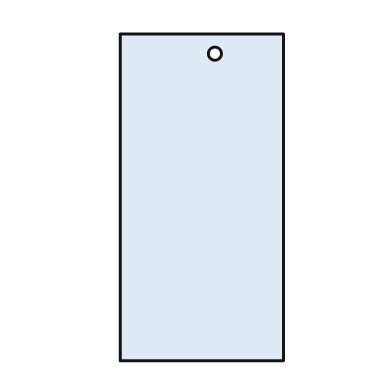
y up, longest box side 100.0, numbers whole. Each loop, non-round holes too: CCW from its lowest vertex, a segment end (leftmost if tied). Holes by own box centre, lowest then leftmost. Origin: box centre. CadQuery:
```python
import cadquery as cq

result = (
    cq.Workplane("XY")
    .moveTo(-25.0, -50.0)
    .lineTo(25.0, -50.0)
    .lineTo(25.0, 50.0)
    .lineTo(-25.0, 50.0)
    .close()
    .moveTo(4.0, 44.0)
    .circle(2.0)
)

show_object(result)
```